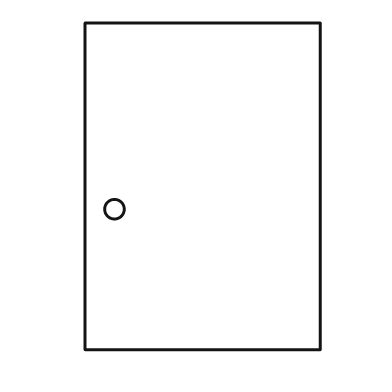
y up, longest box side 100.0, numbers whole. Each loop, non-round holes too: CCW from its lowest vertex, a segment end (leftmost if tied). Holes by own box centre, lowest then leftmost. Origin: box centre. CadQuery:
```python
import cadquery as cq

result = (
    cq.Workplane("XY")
    .moveTo(-36.0, -50.0)
    .lineTo(36.0, -50.0)
    .lineTo(36.0, 50.0)
    .lineTo(-36.0, 50.0)
    .close()
    .moveTo(-27.0, -7.0)
    .circle(3.0)
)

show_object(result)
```